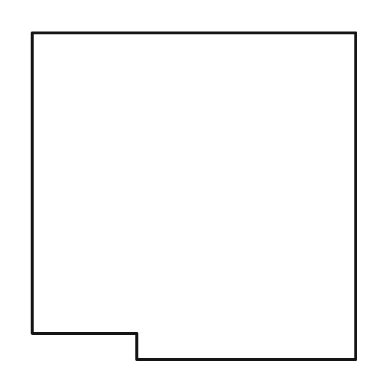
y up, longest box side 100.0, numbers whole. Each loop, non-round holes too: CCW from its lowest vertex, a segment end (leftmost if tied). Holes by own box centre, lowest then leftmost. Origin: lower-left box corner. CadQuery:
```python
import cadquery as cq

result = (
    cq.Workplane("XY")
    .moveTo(32.0, 0.0)
    .lineTo(99.0, 0.0)
    .lineTo(99.0, 100.0)
    .lineTo(0.0, 100.0)
    .lineTo(0.0, 8.0)
    .lineTo(32.0, 8.0)
    .close()
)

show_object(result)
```